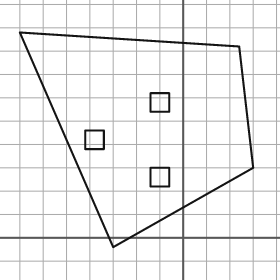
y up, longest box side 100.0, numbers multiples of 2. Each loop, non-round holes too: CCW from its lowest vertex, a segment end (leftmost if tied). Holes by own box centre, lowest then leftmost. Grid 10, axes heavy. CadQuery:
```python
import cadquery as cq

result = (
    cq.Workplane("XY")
    .moveTo(-30.0, -4.0)
    .lineTo(30.0, 30.0)
    .lineTo(24.0, 82.0)
    .lineTo(-70.0, 88.0)
    .close()
    .moveTo(-14.0, 22.0)
    .lineTo(-6.0, 22.0)
    .lineTo(-6.0, 30.0)
    .lineTo(-14.0, 30.0)
    .close()
    .moveTo(-42.0, 38.0)
    .lineTo(-34.0, 38.0)
    .lineTo(-34.0, 46.0)
    .lineTo(-42.0, 46.0)
    .close()
    .moveTo(-14.0, 54.0)
    .lineTo(-6.0, 54.0)
    .lineTo(-6.0, 62.0)
    .lineTo(-14.0, 62.0)
    .close()
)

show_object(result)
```